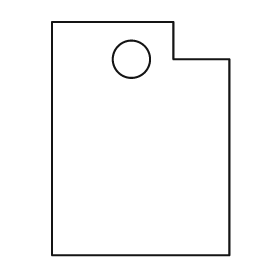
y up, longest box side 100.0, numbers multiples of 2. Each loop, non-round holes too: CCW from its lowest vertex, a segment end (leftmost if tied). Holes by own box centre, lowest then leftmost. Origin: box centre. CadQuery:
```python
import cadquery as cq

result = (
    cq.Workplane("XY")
    .moveTo(-38.0, -50.0)
    .lineTo(38.0, -50.0)
    .lineTo(38.0, 34.0)
    .lineTo(14.0, 34.0)
    .lineTo(14.0, 50.0)
    .lineTo(-38.0, 50.0)
    .close()
    .moveTo(-4.0, 34.0)
    .circle(8.0)
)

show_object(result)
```